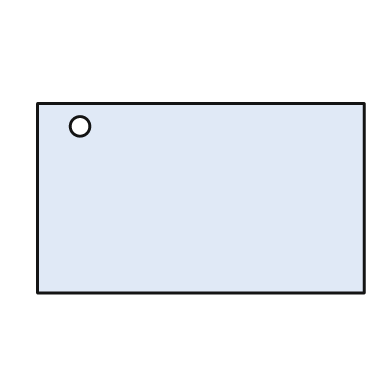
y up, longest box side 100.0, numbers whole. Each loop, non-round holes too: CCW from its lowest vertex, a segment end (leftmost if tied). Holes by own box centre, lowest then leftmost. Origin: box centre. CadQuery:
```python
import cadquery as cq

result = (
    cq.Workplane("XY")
    .moveTo(-50.0, -29.0)
    .lineTo(50.0, -29.0)
    .lineTo(50.0, 29.0)
    .lineTo(-50.0, 29.0)
    .close()
    .moveTo(-37.0, 22.0)
    .circle(3.0)
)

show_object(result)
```